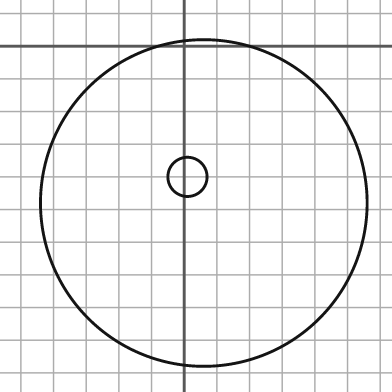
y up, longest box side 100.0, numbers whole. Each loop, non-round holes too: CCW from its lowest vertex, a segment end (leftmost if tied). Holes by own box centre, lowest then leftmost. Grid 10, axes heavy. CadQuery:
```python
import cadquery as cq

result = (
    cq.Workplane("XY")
    .moveTo(6.0, -48.0)
    .circle(50.0)
    .moveTo(1.0, -40.0)
    .circle(6.0)
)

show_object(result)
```